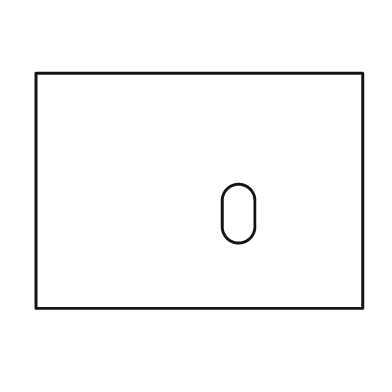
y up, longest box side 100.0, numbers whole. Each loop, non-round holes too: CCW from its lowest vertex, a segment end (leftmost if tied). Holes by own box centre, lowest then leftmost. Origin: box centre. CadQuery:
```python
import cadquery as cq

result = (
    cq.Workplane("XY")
    .moveTo(-50.0, -36.0)
    .lineTo(50.0, -36.0)
    .lineTo(50.0, 36.0)
    .lineTo(-50.0, 36.0)
    .close()
    .moveTo(7.0, -11.0)
    .threePointArc((12.0, -16.0), (17.0, -11.0))
    .lineTo(17.0, -3.0)
    .threePointArc((12.0, 2.0), (7.0, -3.0))
    .close()
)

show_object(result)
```